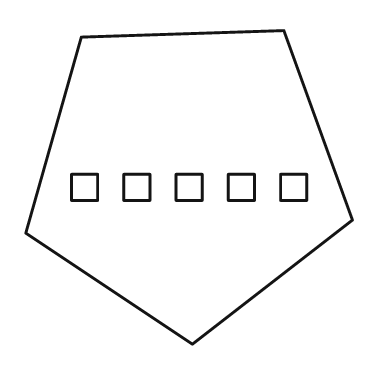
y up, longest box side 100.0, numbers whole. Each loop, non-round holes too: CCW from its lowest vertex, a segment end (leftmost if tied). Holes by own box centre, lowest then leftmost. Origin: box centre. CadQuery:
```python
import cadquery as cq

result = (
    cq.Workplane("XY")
    .moveTo(1.0, -48.0)
    .lineTo(50.0, -10.0)
    .lineTo(29.0, 48.0)
    .lineTo(-33.0, 46.0)
    .lineTo(-50.0, -14.0)
    .close()
    .moveTo(-36.0, -4.0)
    .lineTo(-28.0, -4.0)
    .lineTo(-28.0, 4.0)
    .lineTo(-36.0, 4.0)
    .close()
    .moveTo(-20.0, -4.0)
    .lineTo(-12.0, -4.0)
    .lineTo(-12.0, 4.0)
    .lineTo(-20.0, 4.0)
    .close()
    .moveTo(-4.0, -4.0)
    .lineTo(4.0, -4.0)
    .lineTo(4.0, 4.0)
    .lineTo(-4.0, 4.0)
    .close()
    .moveTo(12.0, -4.0)
    .lineTo(20.0, -4.0)
    .lineTo(20.0, 4.0)
    .lineTo(12.0, 4.0)
    .close()
    .moveTo(28.0, -4.0)
    .lineTo(36.0, -4.0)
    .lineTo(36.0, 4.0)
    .lineTo(28.0, 4.0)
    .close()
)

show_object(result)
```